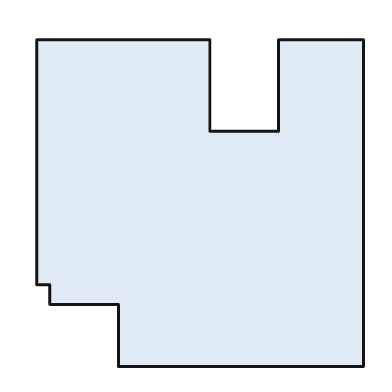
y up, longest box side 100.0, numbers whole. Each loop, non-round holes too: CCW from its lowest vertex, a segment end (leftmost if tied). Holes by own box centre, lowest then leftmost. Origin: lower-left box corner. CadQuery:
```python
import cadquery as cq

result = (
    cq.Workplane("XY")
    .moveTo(25.0, 0.0)
    .lineTo(100.0, 0.0)
    .lineTo(100.0, 100.0)
    .lineTo(74.0, 100.0)
    .lineTo(74.0, 72.0)
    .lineTo(53.0, 72.0)
    .lineTo(53.0, 100.0)
    .lineTo(0.0, 100.0)
    .lineTo(0.0, 25.0)
    .lineTo(4.0, 25.0)
    .lineTo(4.0, 19.0)
    .lineTo(25.0, 19.0)
    .close()
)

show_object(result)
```